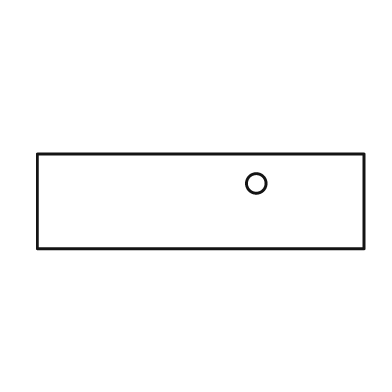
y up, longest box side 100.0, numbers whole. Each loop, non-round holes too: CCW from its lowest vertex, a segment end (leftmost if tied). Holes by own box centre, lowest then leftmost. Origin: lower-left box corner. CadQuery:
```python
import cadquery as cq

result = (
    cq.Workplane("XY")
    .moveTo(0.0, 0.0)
    .lineTo(100.0, 0.0)
    .lineTo(100.0, 29.0)
    .lineTo(0.0, 29.0)
    .close()
    .moveTo(67.0, 20.0)
    .circle(3.0)
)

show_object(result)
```